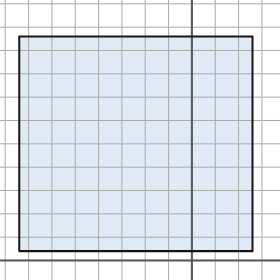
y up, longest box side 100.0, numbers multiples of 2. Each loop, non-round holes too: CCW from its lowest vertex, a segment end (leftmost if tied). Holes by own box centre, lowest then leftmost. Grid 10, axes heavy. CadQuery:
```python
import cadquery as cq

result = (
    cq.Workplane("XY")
    .moveTo(-74.0, 4.0)
    .lineTo(26.0, 4.0)
    .lineTo(26.0, 96.0)
    .lineTo(-74.0, 96.0)
    .close()
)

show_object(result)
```